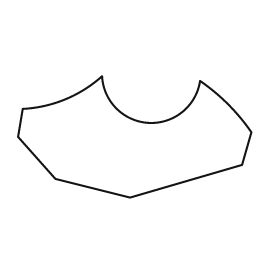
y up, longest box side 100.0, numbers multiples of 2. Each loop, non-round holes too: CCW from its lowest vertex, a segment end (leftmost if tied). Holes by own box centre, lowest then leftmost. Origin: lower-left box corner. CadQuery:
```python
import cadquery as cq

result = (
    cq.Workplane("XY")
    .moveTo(48.0, 0.0)
    .lineTo(96.0, 14.0)
    .lineTo(100.0, 28.0)
    .threePointArc((90.0, 40.0), (78.0, 50.0))
    .threePointArc((56.0, 32.0), (36.0, 52.0))
    .threePointArc((20.0, 42.0), (2.0, 38.0))
    .lineTo(0.0, 26.0)
    .lineTo(16.0, 8.0)
    .close()
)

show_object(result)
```